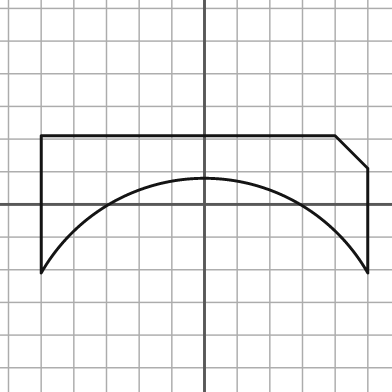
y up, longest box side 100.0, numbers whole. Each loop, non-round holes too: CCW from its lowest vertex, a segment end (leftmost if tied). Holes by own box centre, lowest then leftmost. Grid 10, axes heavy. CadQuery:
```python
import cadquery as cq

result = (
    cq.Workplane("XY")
    .moveTo(-50.0, -21.0)
    .threePointArc((0.0, 8.0), (50.0, -21.0))
    .lineTo(50.0, 11.0)
    .lineTo(40.0, 21.0)
    .lineTo(-50.0, 21.0)
    .close()
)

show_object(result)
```